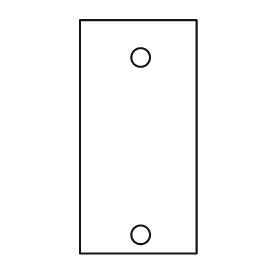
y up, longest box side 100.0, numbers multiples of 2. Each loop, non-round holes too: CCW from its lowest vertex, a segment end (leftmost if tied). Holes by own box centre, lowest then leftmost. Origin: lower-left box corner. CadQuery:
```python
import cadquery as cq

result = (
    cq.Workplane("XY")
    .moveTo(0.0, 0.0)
    .lineTo(50.0, 0.0)
    .lineTo(50.0, 100.0)
    .lineTo(0.0, 100.0)
    .close()
    .moveTo(26.0, 8.0)
    .circle(4.0)
    .moveTo(26.0, 84.0)
    .circle(4.0)
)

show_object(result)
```